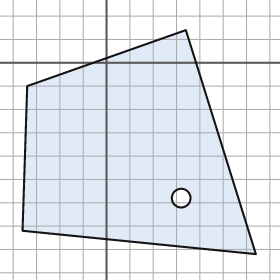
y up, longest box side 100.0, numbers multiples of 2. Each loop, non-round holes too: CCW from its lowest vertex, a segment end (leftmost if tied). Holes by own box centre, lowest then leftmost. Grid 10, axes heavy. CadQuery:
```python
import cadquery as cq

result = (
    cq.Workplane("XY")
    .moveTo(64.0, -82.0)
    .lineTo(34.0, 14.0)
    .lineTo(-34.0, -10.0)
    .lineTo(-36.0, -72.0)
    .close()
    .moveTo(32.0, -58.0)
    .circle(4.0)
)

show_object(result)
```